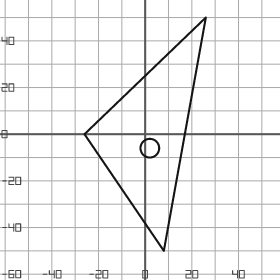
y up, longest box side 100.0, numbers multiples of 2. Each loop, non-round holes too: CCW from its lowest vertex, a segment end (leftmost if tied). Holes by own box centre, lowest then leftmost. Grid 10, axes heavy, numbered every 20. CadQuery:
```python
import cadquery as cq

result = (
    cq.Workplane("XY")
    .moveTo(8.0, -50.0)
    .lineTo(26.0, 50.0)
    .lineTo(-26.0, 0.0)
    .close()
    .moveTo(2.0, -6.0)
    .circle(4.0)
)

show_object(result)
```